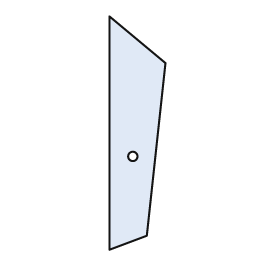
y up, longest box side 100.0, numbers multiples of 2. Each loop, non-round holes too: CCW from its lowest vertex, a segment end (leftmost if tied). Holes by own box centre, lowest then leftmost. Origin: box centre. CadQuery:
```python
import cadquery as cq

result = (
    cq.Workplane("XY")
    .moveTo(-12.0, -50.0)
    .lineTo(4.0, -44.0)
    .lineTo(12.0, 30.0)
    .lineTo(-12.0, 50.0)
    .close()
    .moveTo(-2.0, -10.0)
    .circle(2.0)
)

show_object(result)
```